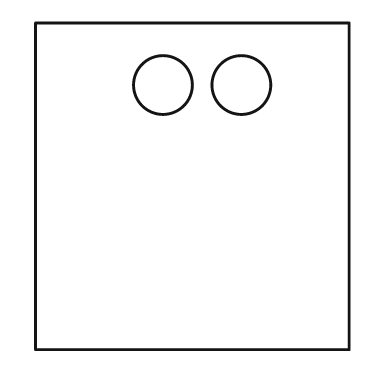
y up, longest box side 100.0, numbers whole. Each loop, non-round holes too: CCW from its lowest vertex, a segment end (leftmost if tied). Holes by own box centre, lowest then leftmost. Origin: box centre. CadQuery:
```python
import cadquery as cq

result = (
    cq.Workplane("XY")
    .moveTo(-48.0, -50.0)
    .lineTo(48.0, -50.0)
    .lineTo(48.0, 50.0)
    .lineTo(-48.0, 50.0)
    .close()
    .moveTo(-9.0, 31.0)
    .circle(9.0)
    .moveTo(15.0, 31.0)
    .circle(9.0)
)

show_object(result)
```